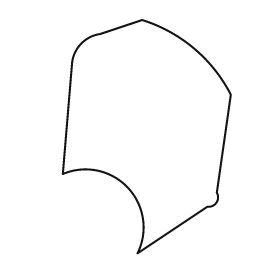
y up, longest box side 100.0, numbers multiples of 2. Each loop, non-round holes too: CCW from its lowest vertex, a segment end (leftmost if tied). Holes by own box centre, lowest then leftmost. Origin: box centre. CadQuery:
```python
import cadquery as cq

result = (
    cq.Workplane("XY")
    .moveTo(-4.0, -50.0)
    .lineTo(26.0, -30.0)
    .threePointArc((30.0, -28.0), (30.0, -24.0))
    .lineTo(36.0, 18.0)
    .threePointArc((20.0, 38.0), (-2.0, 50.0))
    .lineTo(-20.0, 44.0)
    .threePointArc((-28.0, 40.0), (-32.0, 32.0))
    .lineTo(-36.0, -16.0)
    .threePointArc((-8.0, -22.0), (-4.0, -50.0))
    .close()
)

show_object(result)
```